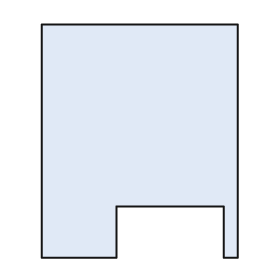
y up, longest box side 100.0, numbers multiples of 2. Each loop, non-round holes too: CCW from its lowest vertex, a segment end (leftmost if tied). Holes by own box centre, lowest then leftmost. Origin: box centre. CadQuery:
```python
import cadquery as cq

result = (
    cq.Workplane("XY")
    .moveTo(-42.0, -50.0)
    .lineTo(-10.0, -50.0)
    .lineTo(-10.0, -28.0)
    .lineTo(36.0, -28.0)
    .lineTo(36.0, -50.0)
    .lineTo(42.0, -50.0)
    .lineTo(42.0, 50.0)
    .lineTo(-42.0, 50.0)
    .close()
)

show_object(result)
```